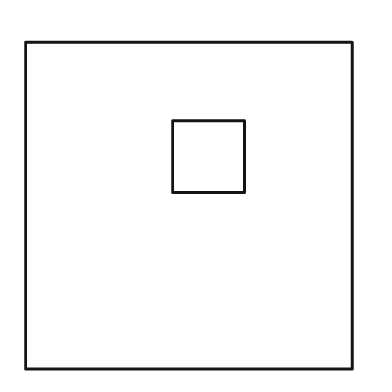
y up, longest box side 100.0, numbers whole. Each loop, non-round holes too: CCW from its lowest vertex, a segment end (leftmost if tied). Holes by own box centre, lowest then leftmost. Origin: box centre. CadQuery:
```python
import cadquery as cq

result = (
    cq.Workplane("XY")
    .moveTo(-50.0, -50.0)
    .lineTo(50.0, -50.0)
    .lineTo(50.0, 50.0)
    .lineTo(-50.0, 50.0)
    .close()
    .moveTo(-5.0, 4.0)
    .lineTo(17.0, 4.0)
    .lineTo(17.0, 26.0)
    .lineTo(-5.0, 26.0)
    .close()
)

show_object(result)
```